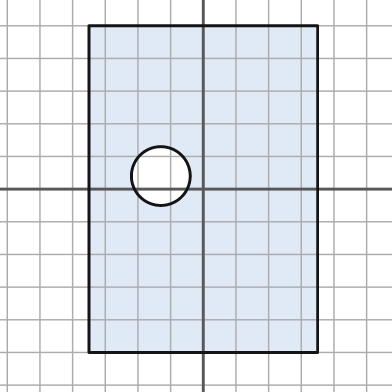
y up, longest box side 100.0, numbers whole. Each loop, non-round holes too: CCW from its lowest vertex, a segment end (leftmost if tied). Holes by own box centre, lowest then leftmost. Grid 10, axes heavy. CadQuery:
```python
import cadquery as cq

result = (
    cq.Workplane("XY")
    .moveTo(-35.0, -50.0)
    .lineTo(35.0, -50.0)
    .lineTo(35.0, 50.0)
    .lineTo(-35.0, 50.0)
    .close()
    .moveTo(-13.0, 4.0)
    .circle(9.0)
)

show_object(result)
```